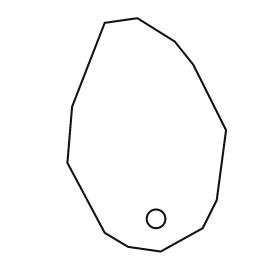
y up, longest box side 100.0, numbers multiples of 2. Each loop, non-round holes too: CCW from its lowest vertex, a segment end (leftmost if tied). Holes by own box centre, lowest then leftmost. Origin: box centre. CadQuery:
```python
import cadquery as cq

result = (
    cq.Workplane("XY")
    .moveTo(6.0, -50.0)
    .lineTo(24.0, -40.0)
    .lineTo(30.0, -28.0)
    .lineTo(34.0, 2.0)
    .lineTo(20.0, 30.0)
    .lineTo(12.0, 40.0)
    .lineTo(-4.0, 50.0)
    .lineTo(-18.0, 48.0)
    .lineTo(-32.0, 12.0)
    .lineTo(-34.0, -12.0)
    .lineTo(-18.0, -42.0)
    .lineTo(-8.0, -48.0)
    .close()
    .moveTo(4.0, -36.0)
    .circle(4.0)
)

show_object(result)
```